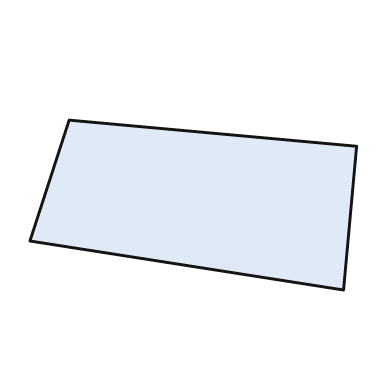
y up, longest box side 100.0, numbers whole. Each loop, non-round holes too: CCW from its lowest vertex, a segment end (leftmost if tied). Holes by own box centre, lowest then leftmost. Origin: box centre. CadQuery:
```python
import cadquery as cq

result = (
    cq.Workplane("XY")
    .moveTo(46.0, -26.0)
    .lineTo(50.0, 18.0)
    .lineTo(-38.0, 26.0)
    .lineTo(-50.0, -11.0)
    .close()
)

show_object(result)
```